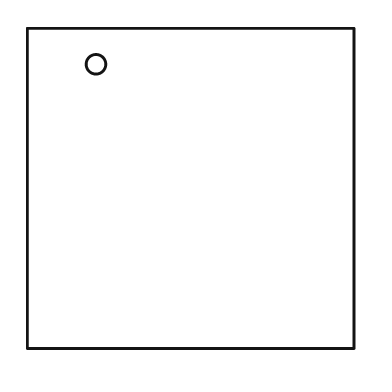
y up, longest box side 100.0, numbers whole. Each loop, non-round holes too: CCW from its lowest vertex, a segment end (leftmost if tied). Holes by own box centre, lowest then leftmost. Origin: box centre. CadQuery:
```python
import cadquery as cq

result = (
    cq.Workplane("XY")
    .moveTo(-50.0, -49.0)
    .lineTo(50.0, -49.0)
    .lineTo(50.0, 49.0)
    .lineTo(-50.0, 49.0)
    .close()
    .moveTo(-29.0, 38.0)
    .circle(3.0)
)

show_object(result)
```